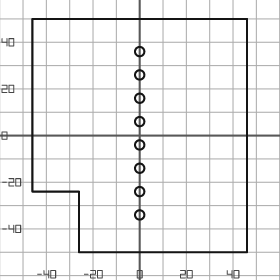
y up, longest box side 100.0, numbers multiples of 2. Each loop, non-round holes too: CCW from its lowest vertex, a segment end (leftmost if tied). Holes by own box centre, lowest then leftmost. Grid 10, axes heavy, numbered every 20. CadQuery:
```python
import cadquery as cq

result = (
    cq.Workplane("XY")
    .moveTo(-26.0, -50.0)
    .lineTo(46.0, -50.0)
    .lineTo(46.0, 50.0)
    .lineTo(-46.0, 50.0)
    .lineTo(-46.0, -24.0)
    .lineTo(-26.0, -24.0)
    .close()
    .moveTo(0.0, -34.0)
    .circle(2.0)
    .moveTo(0.0, -24.0)
    .circle(2.0)
    .moveTo(0.0, -14.0)
    .circle(2.0)
    .moveTo(0.0, -4.0)
    .circle(2.0)
    .moveTo(0.0, 6.0)
    .circle(2.0)
    .moveTo(0.0, 16.0)
    .circle(2.0)
    .moveTo(0.0, 26.0)
    .circle(2.0)
    .moveTo(0.0, 36.0)
    .circle(2.0)
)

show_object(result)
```